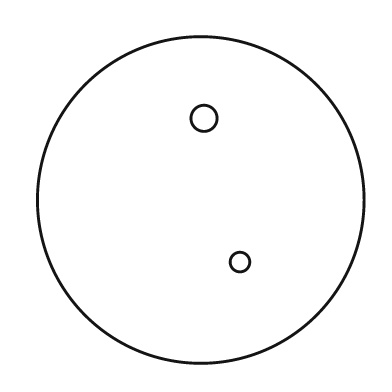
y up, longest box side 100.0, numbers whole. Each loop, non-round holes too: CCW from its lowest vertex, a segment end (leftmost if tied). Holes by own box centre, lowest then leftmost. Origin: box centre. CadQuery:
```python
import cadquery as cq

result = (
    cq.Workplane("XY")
    .moveTo(0.0, 0.0)
    .circle(50.0)
    .moveTo(12.0, -19.0)
    .circle(3.0)
    .moveTo(1.0, 25.0)
    .circle(4.0)
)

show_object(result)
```